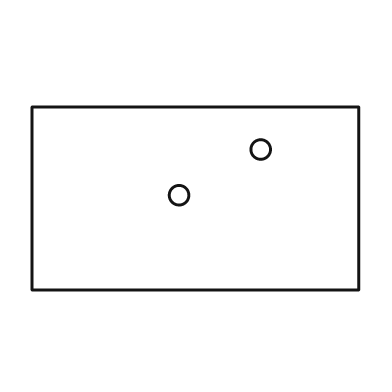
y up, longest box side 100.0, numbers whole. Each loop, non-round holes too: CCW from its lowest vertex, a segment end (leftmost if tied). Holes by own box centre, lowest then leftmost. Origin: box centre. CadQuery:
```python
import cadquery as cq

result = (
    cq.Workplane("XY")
    .moveTo(-50.0, -28.0)
    .lineTo(50.0, -28.0)
    .lineTo(50.0, 28.0)
    .lineTo(-50.0, 28.0)
    .close()
    .moveTo(-5.0, 1.0)
    .circle(3.0)
    .moveTo(20.0, 15.0)
    .circle(3.0)
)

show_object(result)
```